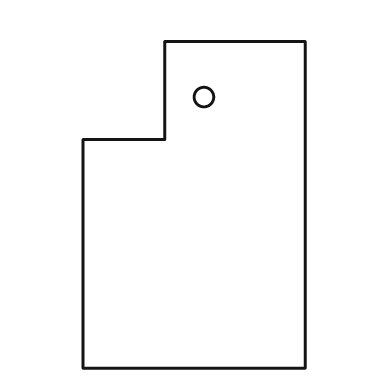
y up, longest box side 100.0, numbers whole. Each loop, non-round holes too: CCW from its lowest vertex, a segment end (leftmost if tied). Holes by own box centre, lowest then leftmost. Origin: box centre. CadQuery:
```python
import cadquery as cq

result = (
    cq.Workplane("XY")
    .moveTo(-34.0, -50.0)
    .lineTo(34.0, -50.0)
    .lineTo(34.0, 50.0)
    .lineTo(-9.0, 50.0)
    .lineTo(-9.0, 20.0)
    .lineTo(-34.0, 20.0)
    .close()
    .moveTo(3.0, 33.0)
    .circle(3.0)
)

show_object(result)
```